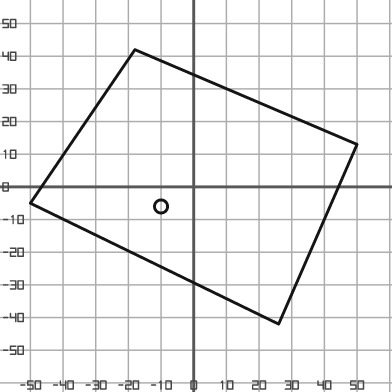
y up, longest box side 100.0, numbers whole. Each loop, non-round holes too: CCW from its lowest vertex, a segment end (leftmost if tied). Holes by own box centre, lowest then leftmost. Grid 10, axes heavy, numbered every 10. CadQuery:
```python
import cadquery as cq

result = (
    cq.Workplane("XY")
    .moveTo(26.0, -42.0)
    .lineTo(50.0, 13.0)
    .lineTo(-18.0, 42.0)
    .lineTo(-50.0, -5.0)
    .close()
    .moveTo(-10.0, -6.0)
    .circle(2.0)
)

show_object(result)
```